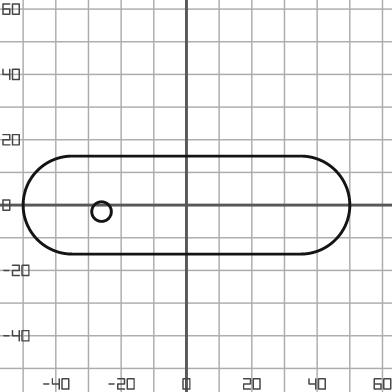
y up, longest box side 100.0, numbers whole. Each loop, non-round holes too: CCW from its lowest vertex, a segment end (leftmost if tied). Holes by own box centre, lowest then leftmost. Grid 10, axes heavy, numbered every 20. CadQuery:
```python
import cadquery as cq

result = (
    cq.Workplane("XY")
    .moveTo(-35.0, -15.0)
    .lineTo(35.0, -15.0)
    .threePointArc((50.0, 0.0), (35.0, 15.0))
    .lineTo(-35.0, 15.0)
    .threePointArc((-50.0, 0.0), (-35.0, -15.0))
    .close()
    .moveTo(-26.0, -2.0)
    .circle(3.0)
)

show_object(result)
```